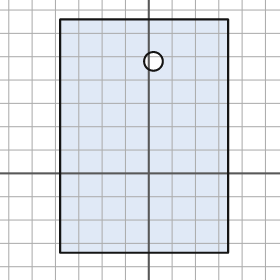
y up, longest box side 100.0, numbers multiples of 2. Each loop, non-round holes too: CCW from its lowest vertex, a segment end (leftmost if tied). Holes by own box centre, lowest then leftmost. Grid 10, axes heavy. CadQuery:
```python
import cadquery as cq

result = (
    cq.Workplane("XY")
    .moveTo(-38.0, -34.0)
    .lineTo(34.0, -34.0)
    .lineTo(34.0, 66.0)
    .lineTo(-38.0, 66.0)
    .close()
    .moveTo(2.0, 48.0)
    .circle(4.0)
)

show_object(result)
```